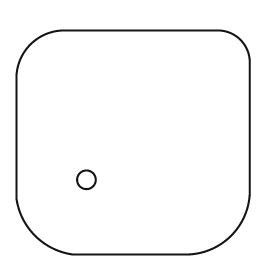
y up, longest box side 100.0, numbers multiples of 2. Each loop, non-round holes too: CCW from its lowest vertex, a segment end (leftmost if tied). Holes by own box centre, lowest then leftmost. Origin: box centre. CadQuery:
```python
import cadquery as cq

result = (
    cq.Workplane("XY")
    .moveTo(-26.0, -48.0)
    .lineTo(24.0, -48.0)
    .threePointArc((42.0, -40.0), (50.0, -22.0))
    .lineTo(50.0, 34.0)
    .threePointArc((46.0, 44.0), (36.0, 48.0))
    .lineTo(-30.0, 48.0)
    .threePointArc((-44.0, 42.0), (-50.0, 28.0))
    .lineTo(-50.0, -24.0)
    .threePointArc((-42.0, -40.0), (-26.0, -48.0))
    .close()
    .moveTo(-20.0, -16.0)
    .circle(4.0)
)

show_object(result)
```